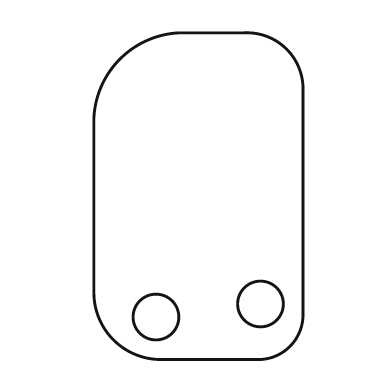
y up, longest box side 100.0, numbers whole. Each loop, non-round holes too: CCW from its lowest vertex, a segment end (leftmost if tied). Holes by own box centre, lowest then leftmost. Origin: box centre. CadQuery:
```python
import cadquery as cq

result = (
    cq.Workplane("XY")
    .moveTo(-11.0, -50.0)
    .lineTo(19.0, -50.0)
    .threePointArc((28.0, -46.0), (32.0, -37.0))
    .lineTo(32.0, 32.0)
    .threePointArc((27.0, 45.0), (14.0, 50.0))
    .lineTo(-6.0, 50.0)
    .threePointArc((-24.0, 42.0), (-32.0, 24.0))
    .lineTo(-32.0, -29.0)
    .threePointArc((-26.0, -44.0), (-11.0, -50.0))
    .close()
    .moveTo(-13.0, -37.0)
    .circle(7.0)
    .moveTo(19.0, -33.0)
    .circle(7.0)
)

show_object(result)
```